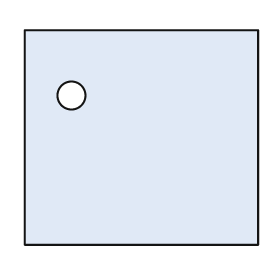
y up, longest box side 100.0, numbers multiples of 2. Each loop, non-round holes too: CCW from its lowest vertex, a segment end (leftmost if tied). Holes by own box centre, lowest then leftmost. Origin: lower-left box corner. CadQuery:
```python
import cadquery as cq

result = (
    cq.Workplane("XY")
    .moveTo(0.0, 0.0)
    .lineTo(100.0, 0.0)
    .lineTo(100.0, 92.0)
    .lineTo(0.0, 92.0)
    .close()
    .moveTo(20.0, 64.0)
    .circle(6.0)
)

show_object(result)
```